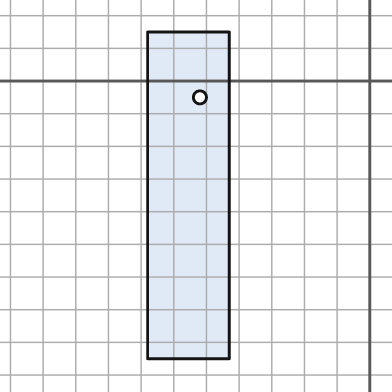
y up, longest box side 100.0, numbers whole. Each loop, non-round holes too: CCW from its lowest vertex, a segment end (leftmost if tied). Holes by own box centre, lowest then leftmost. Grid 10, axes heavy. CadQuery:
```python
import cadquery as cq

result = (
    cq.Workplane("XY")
    .moveTo(-68.0, -85.0)
    .lineTo(-43.0, -85.0)
    .lineTo(-43.0, 15.0)
    .lineTo(-68.0, 15.0)
    .close()
    .moveTo(-52.0, -5.0)
    .circle(2.0)
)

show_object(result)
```